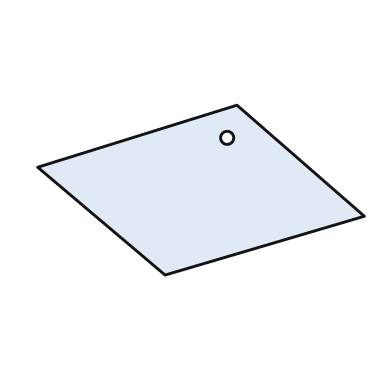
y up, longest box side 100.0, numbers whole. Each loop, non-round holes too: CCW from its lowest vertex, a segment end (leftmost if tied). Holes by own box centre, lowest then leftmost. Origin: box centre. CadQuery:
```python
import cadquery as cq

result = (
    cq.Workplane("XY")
    .moveTo(-11.0, -26.0)
    .lineTo(50.0, -8.0)
    .lineTo(11.0, 26.0)
    .lineTo(-50.0, 7.0)
    .close()
    .moveTo(8.0, 16.0)
    .circle(2.0)
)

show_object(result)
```